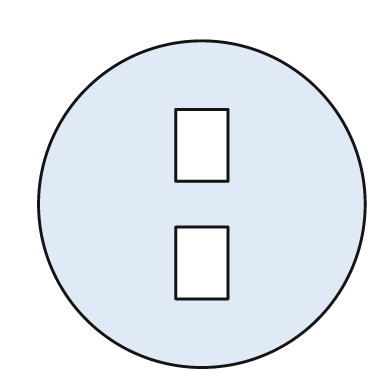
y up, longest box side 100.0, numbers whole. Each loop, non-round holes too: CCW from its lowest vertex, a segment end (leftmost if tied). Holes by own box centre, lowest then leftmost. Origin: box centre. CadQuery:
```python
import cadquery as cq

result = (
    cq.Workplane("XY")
    .moveTo(0.0, 0.0)
    .circle(50.0)
    .moveTo(-8.0, -29.0)
    .lineTo(8.0, -29.0)
    .lineTo(8.0, -7.0)
    .lineTo(-8.0, -7.0)
    .close()
    .moveTo(-8.0, 7.0)
    .lineTo(8.0, 7.0)
    .lineTo(8.0, 29.0)
    .lineTo(-8.0, 29.0)
    .close()
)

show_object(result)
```